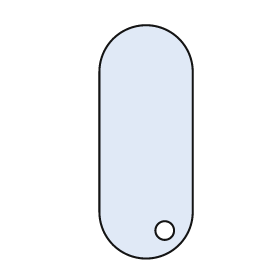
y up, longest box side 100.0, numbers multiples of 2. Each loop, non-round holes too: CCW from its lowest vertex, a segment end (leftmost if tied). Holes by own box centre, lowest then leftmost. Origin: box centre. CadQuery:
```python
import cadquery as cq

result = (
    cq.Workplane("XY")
    .moveTo(-20.0, -30.0)
    .threePointArc((0.0, -50.0), (20.0, -30.0))
    .lineTo(20.0, 30.0)
    .threePointArc((0.0, 50.0), (-20.0, 30.0))
    .close()
    .moveTo(8.0, -38.0)
    .circle(4.0)
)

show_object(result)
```